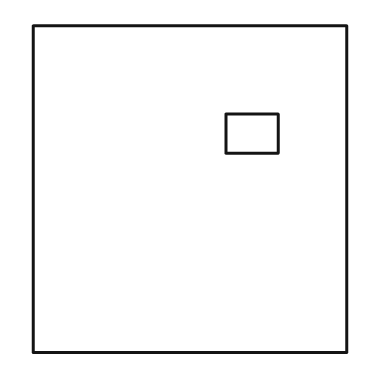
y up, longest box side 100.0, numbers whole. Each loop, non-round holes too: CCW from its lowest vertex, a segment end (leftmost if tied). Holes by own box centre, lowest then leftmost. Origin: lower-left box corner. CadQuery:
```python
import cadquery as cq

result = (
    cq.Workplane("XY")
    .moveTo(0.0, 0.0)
    .lineTo(96.0, 0.0)
    .lineTo(96.0, 100.0)
    .lineTo(0.0, 100.0)
    .close()
    .moveTo(59.0, 61.0)
    .lineTo(75.0, 61.0)
    .lineTo(75.0, 73.0)
    .lineTo(59.0, 73.0)
    .close()
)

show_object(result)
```